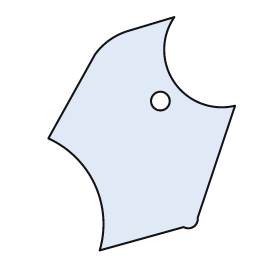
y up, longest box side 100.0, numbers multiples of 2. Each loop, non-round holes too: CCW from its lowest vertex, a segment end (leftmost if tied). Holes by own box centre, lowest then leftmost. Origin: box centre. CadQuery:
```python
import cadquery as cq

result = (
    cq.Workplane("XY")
    .moveTo(-18.0, -50.0)
    .lineTo(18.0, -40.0)
    .threePointArc((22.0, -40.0), (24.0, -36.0))
    .lineTo(40.0, 12.0)
    .threePointArc((14.0, 22.0), (14.0, 50.0))
    .lineTo(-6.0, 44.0)
    .threePointArc((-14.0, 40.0), (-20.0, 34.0))
    .lineTo(-40.0, -2.0)
    .threePointArc((-20.0, -22.0), (-18.0, -50.0))
    .close()
    .moveTo(8.0, 14.0)
    .circle(4.0)
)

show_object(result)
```